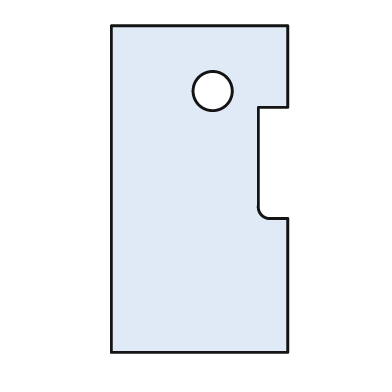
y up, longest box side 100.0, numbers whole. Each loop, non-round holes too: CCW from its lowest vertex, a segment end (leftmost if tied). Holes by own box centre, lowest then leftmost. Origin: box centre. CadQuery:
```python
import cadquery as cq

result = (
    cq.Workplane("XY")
    .moveTo(-27.0, -50.0)
    .lineTo(27.0, -50.0)
    .lineTo(27.0, -9.0)
    .lineTo(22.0, -9.0)
    .threePointArc((19.0, -8.0), (18.0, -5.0))
    .lineTo(18.0, 25.0)
    .lineTo(27.0, 25.0)
    .lineTo(27.0, 50.0)
    .lineTo(-27.0, 50.0)
    .close()
    .moveTo(4.0, 30.0)
    .circle(6.0)
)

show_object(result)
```